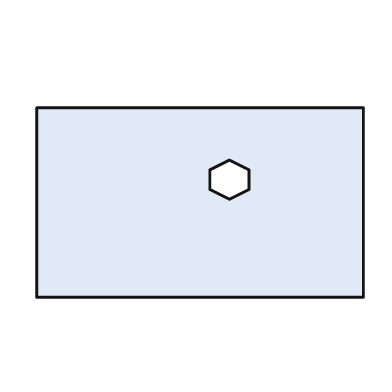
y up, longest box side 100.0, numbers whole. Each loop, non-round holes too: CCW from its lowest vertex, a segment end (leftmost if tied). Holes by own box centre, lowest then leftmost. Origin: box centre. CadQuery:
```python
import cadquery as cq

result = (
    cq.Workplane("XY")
    .moveTo(-50.0, -29.0)
    .lineTo(50.0, -29.0)
    .lineTo(50.0, 29.0)
    .lineTo(-50.0, 29.0)
    .close()
    .moveTo(9.0, 1.0)
    .lineTo(15.0, 4.0)
    .lineTo(15.0, 10.0)
    .lineTo(9.0, 13.0)
    .lineTo(3.0, 10.0)
    .lineTo(3.0, 4.0)
    .close()
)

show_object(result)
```